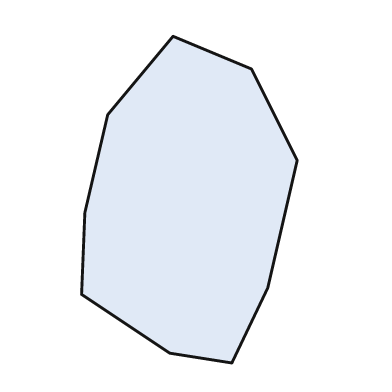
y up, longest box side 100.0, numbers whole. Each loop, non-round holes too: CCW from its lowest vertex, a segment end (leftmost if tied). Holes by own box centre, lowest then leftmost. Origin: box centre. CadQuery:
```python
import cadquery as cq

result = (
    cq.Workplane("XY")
    .moveTo(13.0, -50.0)
    .lineTo(24.0, -27.0)
    .lineTo(33.0, 12.0)
    .lineTo(19.0, 40.0)
    .lineTo(-5.0, 50.0)
    .lineTo(-25.0, 26.0)
    .lineTo(-32.0, -4.0)
    .lineTo(-33.0, -29.0)
    .lineTo(-6.0, -47.0)
    .close()
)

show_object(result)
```